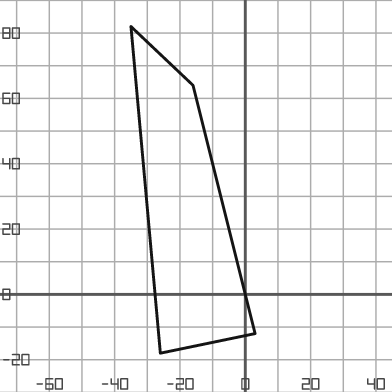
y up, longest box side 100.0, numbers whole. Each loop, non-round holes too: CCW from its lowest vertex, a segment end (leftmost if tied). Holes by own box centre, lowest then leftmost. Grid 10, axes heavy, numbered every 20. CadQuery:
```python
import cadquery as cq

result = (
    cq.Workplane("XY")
    .moveTo(-26.0, -18.0)
    .lineTo(3.0, -12.0)
    .lineTo(-16.0, 64.0)
    .lineTo(-35.0, 82.0)
    .close()
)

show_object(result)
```